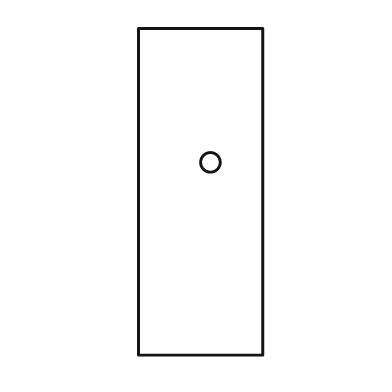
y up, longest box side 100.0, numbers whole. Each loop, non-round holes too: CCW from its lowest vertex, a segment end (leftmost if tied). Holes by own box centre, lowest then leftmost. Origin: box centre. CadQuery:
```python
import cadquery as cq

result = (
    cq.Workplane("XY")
    .moveTo(-19.0, -50.0)
    .lineTo(19.0, -50.0)
    .lineTo(19.0, 50.0)
    .lineTo(-19.0, 50.0)
    .close()
    .moveTo(3.0, 9.0)
    .circle(3.0)
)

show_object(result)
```